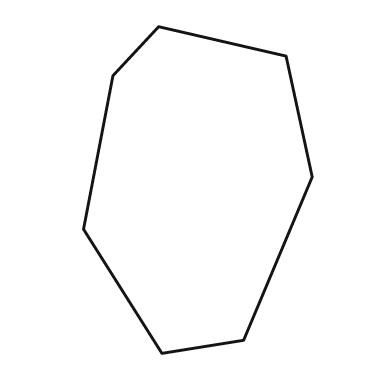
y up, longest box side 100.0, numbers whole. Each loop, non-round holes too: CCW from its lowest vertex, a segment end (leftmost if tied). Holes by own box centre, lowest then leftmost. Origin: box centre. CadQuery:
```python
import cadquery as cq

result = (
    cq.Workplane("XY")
    .moveTo(-11.0, -50.0)
    .lineTo(14.0, -46.0)
    .lineTo(35.0, 4.0)
    .lineTo(27.0, 41.0)
    .lineTo(-12.0, 50.0)
    .lineTo(-26.0, 35.0)
    .lineTo(-35.0, -12.0)
    .close()
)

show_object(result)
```